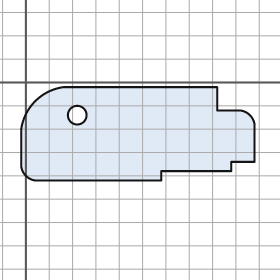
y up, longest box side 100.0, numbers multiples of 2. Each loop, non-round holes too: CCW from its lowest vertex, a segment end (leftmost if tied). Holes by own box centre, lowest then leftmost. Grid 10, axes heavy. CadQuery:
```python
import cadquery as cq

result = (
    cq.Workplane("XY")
    .moveTo(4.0, -42.0)
    .lineTo(58.0, -42.0)
    .lineTo(58.0, -38.0)
    .lineTo(88.0, -38.0)
    .lineTo(88.0, -34.0)
    .lineTo(98.0, -34.0)
    .lineTo(98.0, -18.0)
    .threePointArc((96.0, -14.0), (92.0, -12.0))
    .lineTo(82.0, -12.0)
    .lineTo(82.0, -2.0)
    .lineTo(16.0, -2.0)
    .threePointArc((4.0, -8.0), (-2.0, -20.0))
    .lineTo(-2.0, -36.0)
    .threePointArc((0.0, -40.0), (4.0, -42.0))
    .close()
    .moveTo(22.0, -14.0)
    .circle(4.0)
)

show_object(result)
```